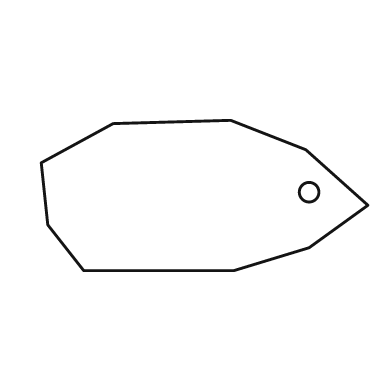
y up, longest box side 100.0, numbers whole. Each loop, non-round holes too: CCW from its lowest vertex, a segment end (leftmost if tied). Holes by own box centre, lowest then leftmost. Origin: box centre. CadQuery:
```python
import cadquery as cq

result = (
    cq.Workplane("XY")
    .moveTo(-37.0, -23.0)
    .lineTo(9.0, -23.0)
    .lineTo(32.0, -16.0)
    .lineTo(50.0, -3.0)
    .lineTo(31.0, 14.0)
    .lineTo(8.0, 23.0)
    .lineTo(-28.0, 22.0)
    .lineTo(-50.0, 10.0)
    .lineTo(-48.0, -9.0)
    .close()
    .moveTo(32.0, 1.0)
    .circle(3.0)
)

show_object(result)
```